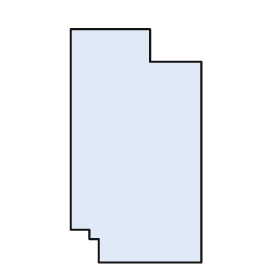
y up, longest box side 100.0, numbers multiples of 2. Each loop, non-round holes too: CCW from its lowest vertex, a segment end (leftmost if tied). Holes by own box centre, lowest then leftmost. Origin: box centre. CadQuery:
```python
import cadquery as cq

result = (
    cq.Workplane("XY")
    .moveTo(-16.0, -50.0)
    .lineTo(28.0, -50.0)
    .lineTo(28.0, 36.0)
    .lineTo(6.0, 36.0)
    .lineTo(6.0, 50.0)
    .lineTo(-28.0, 50.0)
    .lineTo(-28.0, -36.0)
    .lineTo(-20.0, -36.0)
    .lineTo(-20.0, -40.0)
    .lineTo(-16.0, -40.0)
    .close()
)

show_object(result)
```